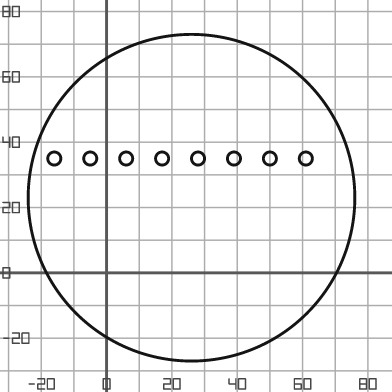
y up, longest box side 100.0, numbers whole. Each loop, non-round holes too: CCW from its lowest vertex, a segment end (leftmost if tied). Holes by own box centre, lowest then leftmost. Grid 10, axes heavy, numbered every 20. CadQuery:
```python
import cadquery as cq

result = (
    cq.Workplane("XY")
    .moveTo(26.0, 23.0)
    .circle(50.0)
    .moveTo(-16.0, 35.0)
    .circle(2.0)
    .moveTo(-5.0, 35.0)
    .circle(2.0)
    .moveTo(6.0, 35.0)
    .circle(2.0)
    .moveTo(17.0, 35.0)
    .circle(2.0)
    .moveTo(28.0, 35.0)
    .circle(2.0)
    .moveTo(39.0, 35.0)
    .circle(2.0)
    .moveTo(50.0, 35.0)
    .circle(2.0)
    .moveTo(61.0, 35.0)
    .circle(2.0)
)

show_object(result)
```